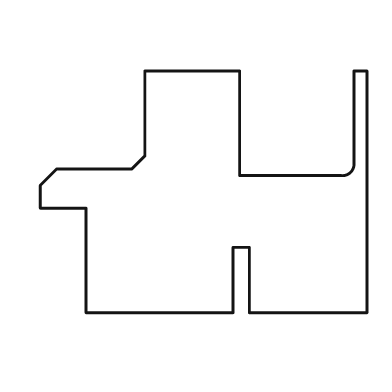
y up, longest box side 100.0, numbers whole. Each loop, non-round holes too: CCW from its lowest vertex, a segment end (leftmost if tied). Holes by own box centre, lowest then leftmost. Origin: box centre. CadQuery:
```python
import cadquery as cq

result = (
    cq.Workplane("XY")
    .moveTo(-36.0, -37.0)
    .lineTo(9.0, -37.0)
    .lineTo(9.0, -17.0)
    .lineTo(14.0, -17.0)
    .lineTo(14.0, -37.0)
    .lineTo(50.0, -37.0)
    .lineTo(50.0, 37.0)
    .lineTo(46.0, 37.0)
    .lineTo(46.0, 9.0)
    .threePointArc((45.0, 6.0), (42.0, 5.0))
    .lineTo(11.0, 5.0)
    .lineTo(11.0, 37.0)
    .lineTo(-18.0, 37.0)
    .lineTo(-18.0, 11.0)
    .lineTo(-22.0, 7.0)
    .lineTo(-45.0, 7.0)
    .lineTo(-50.0, 2.0)
    .lineTo(-50.0, -5.0)
    .lineTo(-36.0, -5.0)
    .close()
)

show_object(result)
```